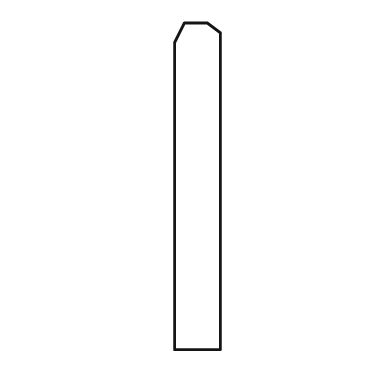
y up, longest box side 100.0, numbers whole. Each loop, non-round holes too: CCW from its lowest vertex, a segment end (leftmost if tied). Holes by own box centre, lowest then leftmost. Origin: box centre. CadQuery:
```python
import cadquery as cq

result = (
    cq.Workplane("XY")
    .moveTo(-7.0, -50.0)
    .lineTo(7.0, -50.0)
    .lineTo(7.0, 47.0)
    .lineTo(3.0, 50.0)
    .lineTo(-4.0, 50.0)
    .lineTo(-7.0, 44.0)
    .close()
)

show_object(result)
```